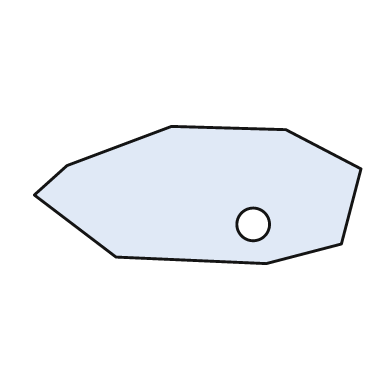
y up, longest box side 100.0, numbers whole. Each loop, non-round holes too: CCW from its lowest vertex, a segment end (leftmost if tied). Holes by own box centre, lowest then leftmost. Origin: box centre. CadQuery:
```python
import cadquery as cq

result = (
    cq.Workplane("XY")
    .moveTo(21.0, -21.0)
    .lineTo(44.0, -15.0)
    .lineTo(50.0, 8.0)
    .lineTo(27.0, 20.0)
    .lineTo(-8.0, 21.0)
    .lineTo(-40.0, 9.0)
    .lineTo(-50.0, 0.0)
    .lineTo(-25.0, -19.0)
    .close()
    .moveTo(17.0, -9.0)
    .circle(5.0)
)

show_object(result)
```